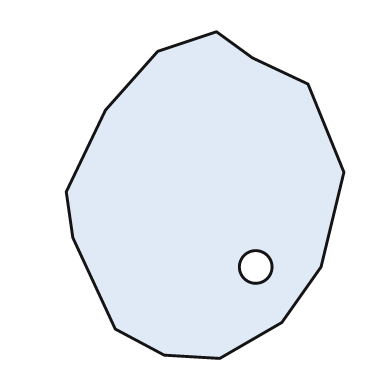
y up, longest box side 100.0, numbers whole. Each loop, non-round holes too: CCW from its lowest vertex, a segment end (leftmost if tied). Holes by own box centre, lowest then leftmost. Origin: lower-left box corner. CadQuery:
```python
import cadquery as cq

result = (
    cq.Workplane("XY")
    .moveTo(47.0, 0.0)
    .lineTo(66.0, 11.0)
    .lineTo(78.0, 28.0)
    .lineTo(85.0, 57.0)
    .lineTo(74.0, 84.0)
    .lineTo(57.0, 92.0)
    .lineTo(46.0, 100.0)
    .lineTo(28.0, 94.0)
    .lineTo(12.0, 76.0)
    .lineTo(0.0, 51.0)
    .lineTo(2.0, 37.0)
    .lineTo(15.0, 9.0)
    .lineTo(30.0, 1.0)
    .close()
    .moveTo(58.0, 28.0)
    .circle(5.0)
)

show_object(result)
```